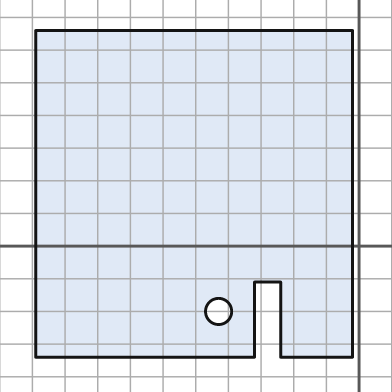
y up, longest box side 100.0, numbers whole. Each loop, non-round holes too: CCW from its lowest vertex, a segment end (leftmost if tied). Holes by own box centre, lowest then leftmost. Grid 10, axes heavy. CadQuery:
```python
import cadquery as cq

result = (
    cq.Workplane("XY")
    .moveTo(-99.0, -34.0)
    .lineTo(-32.0, -34.0)
    .lineTo(-32.0, -11.0)
    .lineTo(-24.0, -11.0)
    .lineTo(-24.0, -34.0)
    .lineTo(-2.0, -34.0)
    .lineTo(-2.0, 66.0)
    .lineTo(-99.0, 66.0)
    .close()
    .moveTo(-43.0, -20.0)
    .circle(4.0)
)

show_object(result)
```